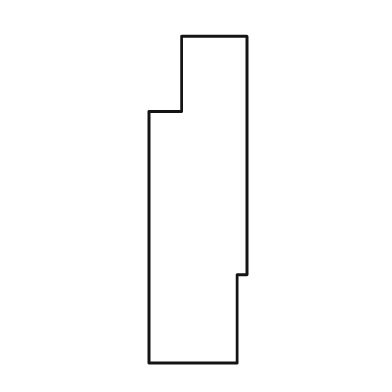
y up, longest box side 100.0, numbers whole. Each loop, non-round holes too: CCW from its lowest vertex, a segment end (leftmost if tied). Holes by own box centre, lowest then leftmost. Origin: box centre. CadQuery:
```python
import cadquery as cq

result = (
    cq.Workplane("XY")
    .moveTo(-15.0, -50.0)
    .lineTo(12.0, -50.0)
    .lineTo(12.0, -23.0)
    .lineTo(15.0, -23.0)
    .lineTo(15.0, 50.0)
    .lineTo(-5.0, 50.0)
    .lineTo(-5.0, 27.0)
    .lineTo(-15.0, 27.0)
    .close()
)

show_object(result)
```